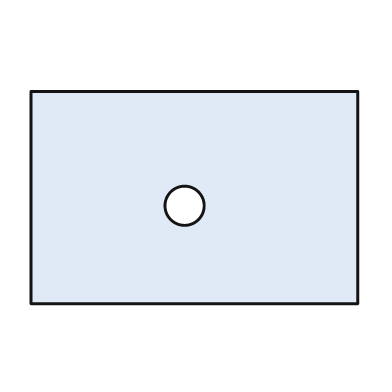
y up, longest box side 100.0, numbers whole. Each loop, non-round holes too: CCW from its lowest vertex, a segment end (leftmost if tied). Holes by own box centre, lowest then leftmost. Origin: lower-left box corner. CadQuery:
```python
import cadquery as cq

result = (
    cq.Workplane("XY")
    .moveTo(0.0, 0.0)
    .lineTo(100.0, 0.0)
    .lineTo(100.0, 65.0)
    .lineTo(0.0, 65.0)
    .close()
    .moveTo(47.0, 30.0)
    .circle(6.0)
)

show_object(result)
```